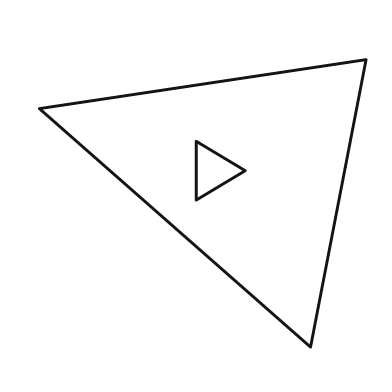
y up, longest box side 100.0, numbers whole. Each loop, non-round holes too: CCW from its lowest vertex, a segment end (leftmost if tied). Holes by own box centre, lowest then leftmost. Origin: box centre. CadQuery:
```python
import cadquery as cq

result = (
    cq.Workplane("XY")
    .moveTo(33.0, -44.0)
    .lineTo(50.0, 44.0)
    .lineTo(-50.0, 29.0)
    .close()
    .moveTo(-2.0, 1.0)
    .lineTo(13.0, 10.0)
    .lineTo(-2.0, 19.0)
    .close()
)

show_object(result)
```